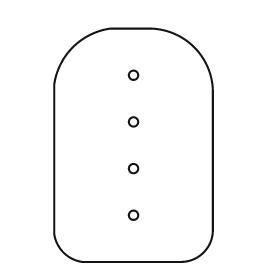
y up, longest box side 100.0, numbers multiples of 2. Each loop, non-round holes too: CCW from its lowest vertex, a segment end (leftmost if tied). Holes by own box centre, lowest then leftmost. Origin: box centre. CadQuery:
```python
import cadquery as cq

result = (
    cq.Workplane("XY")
    .moveTo(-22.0, -50.0)
    .lineTo(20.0, -50.0)
    .threePointArc((30.0, -46.0), (34.0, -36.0))
    .lineTo(34.0, 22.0)
    .threePointArc((26.0, 42.0), (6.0, 50.0))
    .lineTo(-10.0, 50.0)
    .threePointArc((-26.0, 42.0), (-34.0, 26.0))
    .lineTo(-34.0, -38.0)
    .threePointArc((-30.0, -46.0), (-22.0, -50.0))
    .close()
    .moveTo(0.0, -30.0)
    .circle(2.0)
    .moveTo(0.0, -10.0)
    .circle(2.0)
    .moveTo(0.0, 10.0)
    .circle(2.0)
    .moveTo(0.0, 30.0)
    .circle(2.0)
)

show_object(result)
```